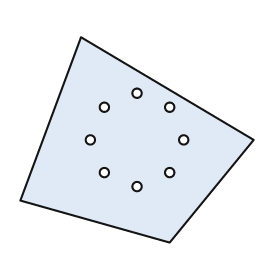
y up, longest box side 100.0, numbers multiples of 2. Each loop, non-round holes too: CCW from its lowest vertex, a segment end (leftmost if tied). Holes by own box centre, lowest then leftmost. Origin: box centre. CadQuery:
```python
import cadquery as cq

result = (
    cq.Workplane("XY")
    .moveTo(14.0, -44.0)
    .lineTo(50.0, 0.0)
    .lineTo(-24.0, 44.0)
    .lineTo(-50.0, -26.0)
    .close()
    .moveTo(0.0, -20.0)
    .circle(2.0)
    .moveTo(-14.0, -14.0)
    .circle(2.0)
    .moveTo(14.0, -14.0)
    .circle(2.0)
    .moveTo(-20.0, 0.0)
    .circle(2.0)
    .moveTo(20.0, 0.0)
    .circle(2.0)
    .moveTo(-14.0, 14.0)
    .circle(2.0)
    .moveTo(14.0, 14.0)
    .circle(2.0)
    .moveTo(0.0, 20.0)
    .circle(2.0)
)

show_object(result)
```